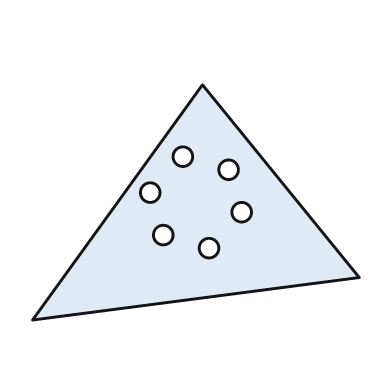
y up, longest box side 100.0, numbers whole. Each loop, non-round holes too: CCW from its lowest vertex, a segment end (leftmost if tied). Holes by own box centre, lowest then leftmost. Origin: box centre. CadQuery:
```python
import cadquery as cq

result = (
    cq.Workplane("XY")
    .moveTo(-50.0, -36.0)
    .lineTo(50.0, -23.0)
    .lineTo(2.0, 36.0)
    .close()
    .moveTo(4.0, -14.0)
    .circle(3.0)
    .moveTo(-10.0, -10.0)
    .circle(3.0)
    .moveTo(14.0, -3.0)
    .circle(3.0)
    .moveTo(-14.0, 3.0)
    .circle(3.0)
    .moveTo(10.0, 10.0)
    .circle(3.0)
    .moveTo(-4.0, 14.0)
    .circle(3.0)
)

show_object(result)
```